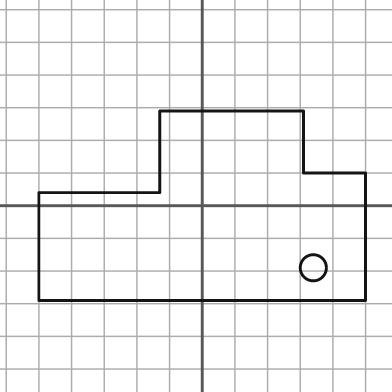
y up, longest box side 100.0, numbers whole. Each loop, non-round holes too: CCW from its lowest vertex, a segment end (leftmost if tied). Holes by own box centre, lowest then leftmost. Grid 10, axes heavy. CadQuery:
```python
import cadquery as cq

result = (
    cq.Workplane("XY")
    .moveTo(-50.0, -29.0)
    .lineTo(50.0, -29.0)
    .lineTo(50.0, 10.0)
    .lineTo(31.0, 10.0)
    .lineTo(31.0, 29.0)
    .lineTo(-13.0, 29.0)
    .lineTo(-13.0, 4.0)
    .lineTo(-50.0, 4.0)
    .close()
    .moveTo(34.0, -19.0)
    .circle(4.0)
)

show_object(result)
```